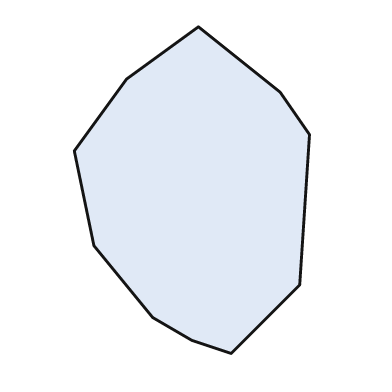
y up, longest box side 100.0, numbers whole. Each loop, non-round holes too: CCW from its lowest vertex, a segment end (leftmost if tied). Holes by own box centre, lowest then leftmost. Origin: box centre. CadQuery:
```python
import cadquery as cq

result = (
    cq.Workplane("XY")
    .moveTo(12.0, -50.0)
    .lineTo(33.0, -29.0)
    .lineTo(36.0, 17.0)
    .lineTo(27.0, 30.0)
    .lineTo(2.0, 50.0)
    .lineTo(-20.0, 34.0)
    .lineTo(-36.0, 12.0)
    .lineTo(-30.0, -17.0)
    .lineTo(-12.0, -39.0)
    .lineTo(0.0, -46.0)
    .close()
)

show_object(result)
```